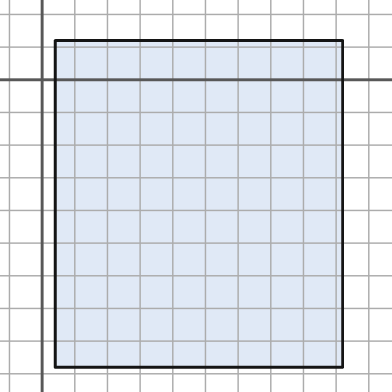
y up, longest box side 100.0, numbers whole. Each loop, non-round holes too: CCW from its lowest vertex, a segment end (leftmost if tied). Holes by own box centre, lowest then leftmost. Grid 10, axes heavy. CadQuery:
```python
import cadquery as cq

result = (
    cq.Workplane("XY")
    .moveTo(4.0, -88.0)
    .lineTo(92.0, -88.0)
    .lineTo(92.0, 12.0)
    .lineTo(4.0, 12.0)
    .close()
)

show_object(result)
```